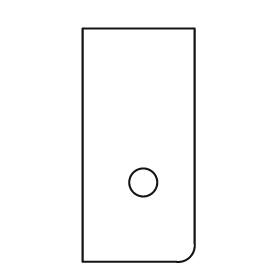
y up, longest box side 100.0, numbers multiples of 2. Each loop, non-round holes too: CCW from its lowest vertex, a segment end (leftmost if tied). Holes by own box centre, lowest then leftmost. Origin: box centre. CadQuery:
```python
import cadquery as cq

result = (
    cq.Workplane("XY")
    .moveTo(-24.0, -50.0)
    .lineTo(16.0, -50.0)
    .threePointArc((22.0, -48.0), (24.0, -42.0))
    .lineTo(24.0, 50.0)
    .lineTo(-24.0, 50.0)
    .close()
    .moveTo(2.0, -16.0)
    .circle(6.0)
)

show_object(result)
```